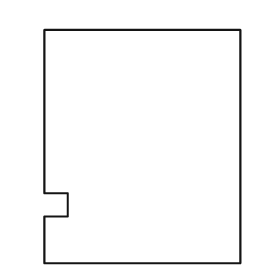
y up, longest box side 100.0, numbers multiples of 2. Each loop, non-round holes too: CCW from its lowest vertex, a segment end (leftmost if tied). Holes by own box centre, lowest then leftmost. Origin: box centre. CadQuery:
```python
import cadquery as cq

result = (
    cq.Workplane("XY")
    .moveTo(-42.0, -50.0)
    .lineTo(42.0, -50.0)
    .lineTo(42.0, 50.0)
    .lineTo(-42.0, 50.0)
    .lineTo(-42.0, -20.0)
    .lineTo(-32.0, -20.0)
    .lineTo(-32.0, -30.0)
    .lineTo(-42.0, -30.0)
    .close()
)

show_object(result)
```